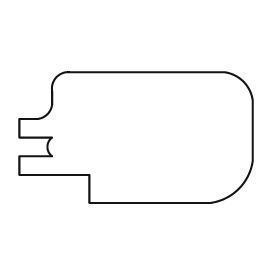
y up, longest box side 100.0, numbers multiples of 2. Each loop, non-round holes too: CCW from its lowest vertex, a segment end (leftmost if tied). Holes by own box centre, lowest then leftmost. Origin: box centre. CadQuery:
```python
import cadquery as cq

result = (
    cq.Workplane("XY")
    .moveTo(-20.0, -28.0)
    .lineTo(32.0, -28.0)
    .threePointArc((44.0, -22.0), (50.0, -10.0))
    .lineTo(50.0, 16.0)
    .threePointArc((46.0, 24.0), (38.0, 28.0))
    .lineTo(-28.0, 28.0)
    .threePointArc((-34.0, 26.0), (-36.0, 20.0))
    .lineTo(-36.0, 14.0)
    .threePointArc((-38.0, 10.0), (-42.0, 8.0))
    .lineTo(-50.0, 8.0)
    .lineTo(-50.0, 0.0)
    .lineTo(-36.0, 0.0)
    .threePointArc((-38.0, -4.0), (-36.0, -8.0))
    .lineTo(-50.0, -8.0)
    .lineTo(-50.0, -16.0)
    .lineTo(-20.0, -16.0)
    .close()
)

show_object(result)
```